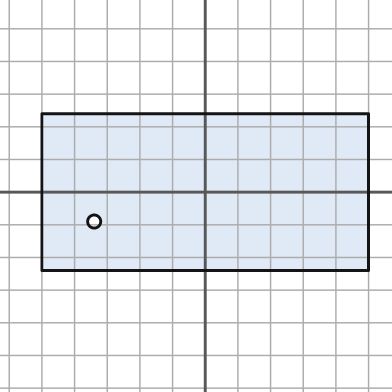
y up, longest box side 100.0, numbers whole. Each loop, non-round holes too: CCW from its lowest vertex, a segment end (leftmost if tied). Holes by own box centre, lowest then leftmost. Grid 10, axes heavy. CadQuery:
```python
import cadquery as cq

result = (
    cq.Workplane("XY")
    .moveTo(-50.0, -24.0)
    .lineTo(50.0, -24.0)
    .lineTo(50.0, 24.0)
    .lineTo(-50.0, 24.0)
    .close()
    .moveTo(-34.0, -9.0)
    .circle(2.0)
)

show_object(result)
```